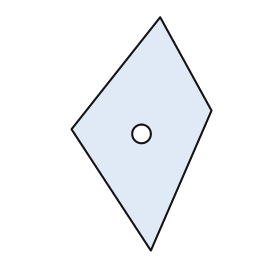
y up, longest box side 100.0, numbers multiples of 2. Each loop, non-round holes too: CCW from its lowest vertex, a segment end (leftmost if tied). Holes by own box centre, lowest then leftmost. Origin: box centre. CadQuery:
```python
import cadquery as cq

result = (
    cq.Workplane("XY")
    .moveTo(4.0, -50.0)
    .lineTo(30.0, 10.0)
    .lineTo(8.0, 50.0)
    .lineTo(-30.0, 2.0)
    .close()
    .moveTo(0.0, 0.0)
    .circle(4.0)
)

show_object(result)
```